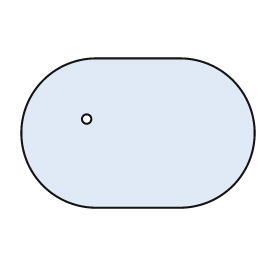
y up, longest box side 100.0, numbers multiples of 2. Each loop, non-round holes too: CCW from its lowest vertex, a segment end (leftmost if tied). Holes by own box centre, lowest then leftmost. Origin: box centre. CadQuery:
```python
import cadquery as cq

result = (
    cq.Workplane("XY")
    .moveTo(-18.0, -32.0)
    .lineTo(18.0, -32.0)
    .threePointArc((50.0, 0.0), (18.0, 32.0))
    .lineTo(-18.0, 32.0)
    .threePointArc((-50.0, 0.0), (-18.0, -32.0))
    .close()
    .moveTo(-22.0, 6.0)
    .circle(2.0)
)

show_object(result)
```